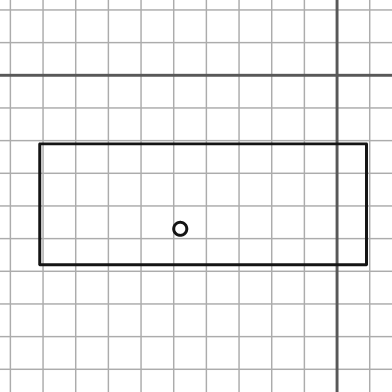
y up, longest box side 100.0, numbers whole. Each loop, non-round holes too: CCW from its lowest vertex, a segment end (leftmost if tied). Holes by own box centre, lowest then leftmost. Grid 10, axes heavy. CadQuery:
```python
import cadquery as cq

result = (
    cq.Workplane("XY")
    .moveTo(-91.0, -58.0)
    .lineTo(9.0, -58.0)
    .lineTo(9.0, -21.0)
    .lineTo(-91.0, -21.0)
    .close()
    .moveTo(-48.0, -47.0)
    .circle(2.0)
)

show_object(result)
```